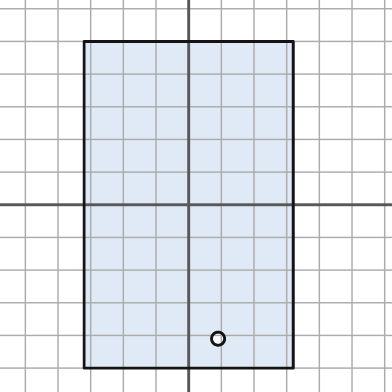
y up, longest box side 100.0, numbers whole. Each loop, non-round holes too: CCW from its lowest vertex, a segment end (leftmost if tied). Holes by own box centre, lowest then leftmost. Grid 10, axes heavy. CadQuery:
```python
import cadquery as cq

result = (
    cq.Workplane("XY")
    .moveTo(-32.0, -50.0)
    .lineTo(32.0, -50.0)
    .lineTo(32.0, 50.0)
    .lineTo(-32.0, 50.0)
    .close()
    .moveTo(9.0, -41.0)
    .circle(2.0)
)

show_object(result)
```